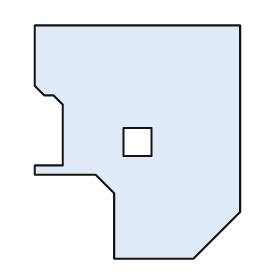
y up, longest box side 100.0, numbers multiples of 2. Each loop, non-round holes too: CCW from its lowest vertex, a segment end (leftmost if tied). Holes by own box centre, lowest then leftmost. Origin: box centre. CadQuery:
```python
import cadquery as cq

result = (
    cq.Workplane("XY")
    .moveTo(-10.0, -50.0)
    .lineTo(24.0, -50.0)
    .lineTo(44.0, -30.0)
    .lineTo(44.0, 50.0)
    .lineTo(-44.0, 50.0)
    .lineTo(-44.0, 24.0)
    .lineTo(-40.0, 20.0)
    .lineTo(-36.0, 20.0)
    .lineTo(-32.0, 16.0)
    .lineTo(-32.0, -10.0)
    .lineTo(-44.0, -10.0)
    .lineTo(-44.0, -14.0)
    .lineTo(-18.0, -14.0)
    .lineTo(-10.0, -22.0)
    .close()
    .moveTo(-6.0, -6.0)
    .lineTo(6.0, -6.0)
    .lineTo(6.0, 6.0)
    .lineTo(-6.0, 6.0)
    .close()
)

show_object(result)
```